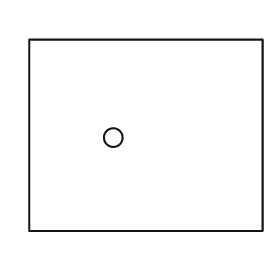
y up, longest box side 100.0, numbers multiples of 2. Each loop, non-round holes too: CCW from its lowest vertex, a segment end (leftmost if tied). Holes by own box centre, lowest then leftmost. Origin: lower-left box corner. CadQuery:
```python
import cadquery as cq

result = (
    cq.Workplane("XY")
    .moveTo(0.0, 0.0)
    .lineTo(100.0, 0.0)
    .lineTo(100.0, 82.0)
    .lineTo(0.0, 82.0)
    .close()
    .moveTo(36.0, 40.0)
    .circle(4.0)
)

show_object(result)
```